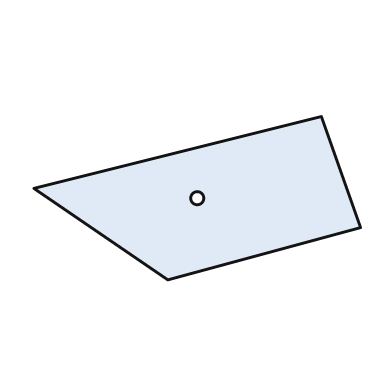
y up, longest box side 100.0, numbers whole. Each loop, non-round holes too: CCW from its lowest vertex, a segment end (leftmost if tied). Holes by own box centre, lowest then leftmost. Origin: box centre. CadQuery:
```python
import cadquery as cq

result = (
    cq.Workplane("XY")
    .moveTo(-9.0, -25.0)
    .lineTo(50.0, -9.0)
    .lineTo(38.0, 25.0)
    .lineTo(-50.0, 3.0)
    .close()
    .moveTo(0.0, 0.0)
    .circle(2.0)
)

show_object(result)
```